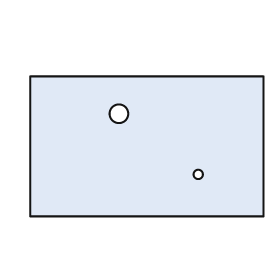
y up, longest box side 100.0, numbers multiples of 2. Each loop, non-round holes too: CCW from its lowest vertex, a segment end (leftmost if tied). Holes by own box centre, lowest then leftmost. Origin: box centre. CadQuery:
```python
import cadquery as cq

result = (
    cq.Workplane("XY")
    .moveTo(-50.0, -30.0)
    .lineTo(50.0, -30.0)
    .lineTo(50.0, 30.0)
    .lineTo(-50.0, 30.0)
    .close()
    .moveTo(22.0, -12.0)
    .circle(2.0)
    .moveTo(-12.0, 14.0)
    .circle(4.0)
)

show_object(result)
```